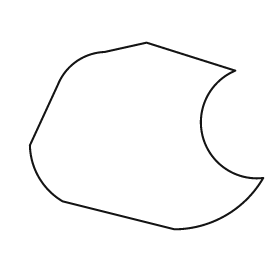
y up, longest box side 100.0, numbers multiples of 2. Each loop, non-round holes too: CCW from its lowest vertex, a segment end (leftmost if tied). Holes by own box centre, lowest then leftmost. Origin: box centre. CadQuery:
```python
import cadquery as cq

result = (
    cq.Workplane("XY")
    .moveTo(12.0, -40.0)
    .threePointArc((34.0, -34.0), (50.0, -18.0))
    .threePointArc((24.0, 0.0), (38.0, 28.0))
    .lineTo(0.0, 40.0)
    .lineTo(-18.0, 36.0)
    .threePointArc((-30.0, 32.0), (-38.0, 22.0))
    .lineTo(-50.0, -4.0)
    .threePointArc((-46.0, -18.0), (-36.0, -28.0))
    .close()
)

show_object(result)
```